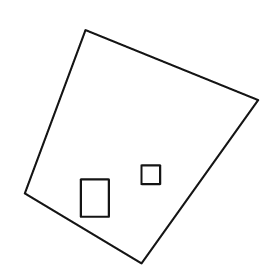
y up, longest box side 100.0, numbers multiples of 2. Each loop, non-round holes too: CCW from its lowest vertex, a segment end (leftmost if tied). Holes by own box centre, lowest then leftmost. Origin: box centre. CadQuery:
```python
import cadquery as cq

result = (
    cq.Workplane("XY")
    .moveTo(0.0, -50.0)
    .lineTo(50.0, 20.0)
    .lineTo(-24.0, 50.0)
    .lineTo(-50.0, -20.0)
    .close()
    .moveTo(-26.0, -30.0)
    .lineTo(-14.0, -30.0)
    .lineTo(-14.0, -14.0)
    .lineTo(-26.0, -14.0)
    .close()
    .moveTo(0.0, -16.0)
    .lineTo(8.0, -16.0)
    .lineTo(8.0, -8.0)
    .lineTo(0.0, -8.0)
    .close()
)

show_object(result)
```